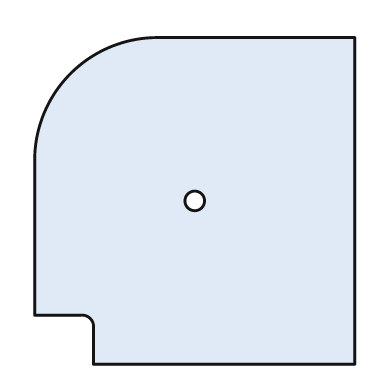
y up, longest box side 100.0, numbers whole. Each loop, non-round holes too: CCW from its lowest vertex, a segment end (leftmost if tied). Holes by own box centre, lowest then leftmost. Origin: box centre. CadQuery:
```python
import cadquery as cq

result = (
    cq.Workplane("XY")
    .moveTo(-31.0, -50.0)
    .lineTo(49.0, -50.0)
    .lineTo(49.0, 50.0)
    .lineTo(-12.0, 50.0)
    .threePointArc((-38.0, 39.0), (-49.0, 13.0))
    .lineTo(-49.0, -35.0)
    .lineTo(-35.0, -35.0)
    .threePointArc((-32.0, -36.0), (-31.0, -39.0))
    .close()
    .moveTo(0.0, 0.0)
    .circle(3.0)
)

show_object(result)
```